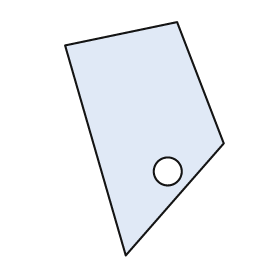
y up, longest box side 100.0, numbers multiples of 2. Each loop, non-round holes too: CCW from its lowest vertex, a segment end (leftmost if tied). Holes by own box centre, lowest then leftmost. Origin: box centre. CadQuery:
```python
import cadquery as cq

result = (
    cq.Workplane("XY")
    .moveTo(-8.0, -50.0)
    .lineTo(34.0, -2.0)
    .lineTo(14.0, 50.0)
    .lineTo(-34.0, 40.0)
    .close()
    .moveTo(10.0, -14.0)
    .circle(6.0)
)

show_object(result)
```